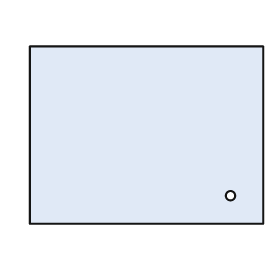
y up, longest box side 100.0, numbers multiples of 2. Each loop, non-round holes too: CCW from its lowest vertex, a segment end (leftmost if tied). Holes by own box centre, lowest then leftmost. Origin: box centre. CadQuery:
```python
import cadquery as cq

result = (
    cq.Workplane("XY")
    .moveTo(-50.0, -38.0)
    .lineTo(50.0, -38.0)
    .lineTo(50.0, 38.0)
    .lineTo(-50.0, 38.0)
    .close()
    .moveTo(36.0, -26.0)
    .circle(2.0)
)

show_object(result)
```